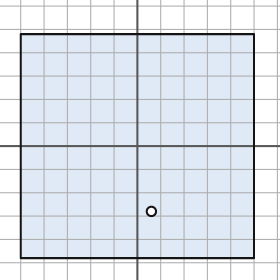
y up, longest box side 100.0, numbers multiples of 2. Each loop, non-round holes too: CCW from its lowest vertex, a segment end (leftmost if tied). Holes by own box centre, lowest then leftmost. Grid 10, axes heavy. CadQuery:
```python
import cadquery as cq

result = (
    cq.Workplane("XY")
    .moveTo(-50.0, -48.0)
    .lineTo(50.0, -48.0)
    .lineTo(50.0, 48.0)
    .lineTo(-50.0, 48.0)
    .close()
    .moveTo(6.0, -28.0)
    .circle(2.0)
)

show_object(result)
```